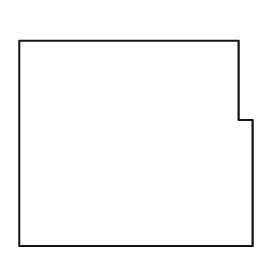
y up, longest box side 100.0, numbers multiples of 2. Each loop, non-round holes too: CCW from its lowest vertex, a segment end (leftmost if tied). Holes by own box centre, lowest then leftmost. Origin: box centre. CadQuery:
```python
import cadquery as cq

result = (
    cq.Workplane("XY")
    .moveTo(-50.0, -44.0)
    .lineTo(50.0, -44.0)
    .lineTo(50.0, 10.0)
    .lineTo(44.0, 10.0)
    .lineTo(44.0, 44.0)
    .lineTo(-50.0, 44.0)
    .close()
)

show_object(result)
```